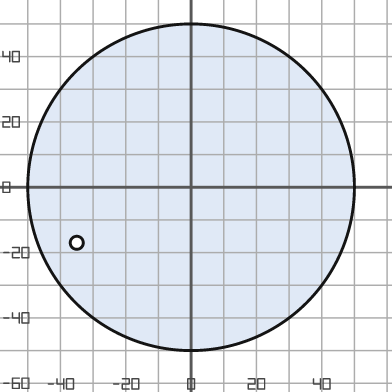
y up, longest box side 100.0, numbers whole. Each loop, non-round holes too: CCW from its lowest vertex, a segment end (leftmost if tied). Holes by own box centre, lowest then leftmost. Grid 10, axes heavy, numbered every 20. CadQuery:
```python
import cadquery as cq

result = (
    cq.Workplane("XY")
    .moveTo(0.0, 0.0)
    .circle(50.0)
    .moveTo(-35.0, -17.0)
    .circle(2.0)
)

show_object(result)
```